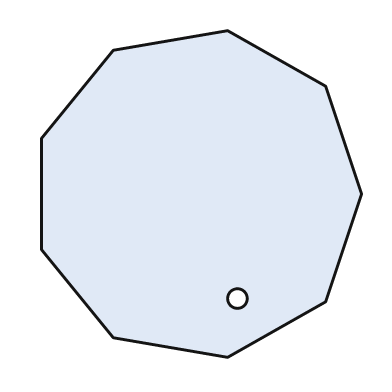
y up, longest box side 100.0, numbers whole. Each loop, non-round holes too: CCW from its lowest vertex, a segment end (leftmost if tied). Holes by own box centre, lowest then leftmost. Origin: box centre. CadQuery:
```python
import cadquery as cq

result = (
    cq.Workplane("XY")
    .moveTo(8.0, -50.0)
    .lineTo(38.0, -33.0)
    .lineTo(49.0, 0.0)
    .lineTo(38.0, 33.0)
    .lineTo(8.0, 50.0)
    .lineTo(-27.0, 44.0)
    .lineTo(-49.0, 17.0)
    .lineTo(-49.0, -17.0)
    .lineTo(-27.0, -44.0)
    .close()
    .moveTo(11.0, -32.0)
    .circle(3.0)
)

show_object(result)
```